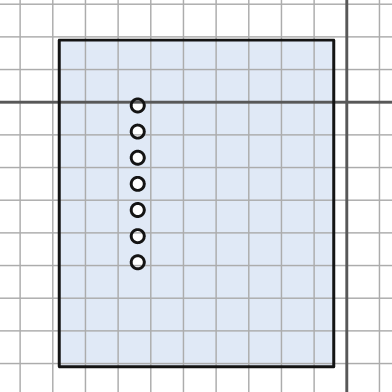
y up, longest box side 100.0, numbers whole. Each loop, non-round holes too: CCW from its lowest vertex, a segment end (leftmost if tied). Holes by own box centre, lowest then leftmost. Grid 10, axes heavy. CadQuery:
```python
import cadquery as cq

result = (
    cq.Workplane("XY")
    .moveTo(-88.0, -81.0)
    .lineTo(-4.0, -81.0)
    .lineTo(-4.0, 19.0)
    .lineTo(-88.0, 19.0)
    .close()
    .moveTo(-64.0, -49.0)
    .circle(2.0)
    .moveTo(-64.0, -41.0)
    .circle(2.0)
    .moveTo(-64.0, -33.0)
    .circle(2.0)
    .moveTo(-64.0, -25.0)
    .circle(2.0)
    .moveTo(-64.0, -17.0)
    .circle(2.0)
    .moveTo(-64.0, -9.0)
    .circle(2.0)
    .moveTo(-64.0, -1.0)
    .circle(2.0)
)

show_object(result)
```